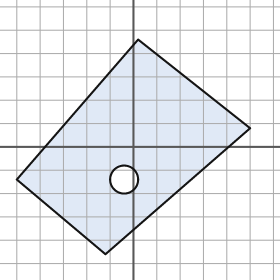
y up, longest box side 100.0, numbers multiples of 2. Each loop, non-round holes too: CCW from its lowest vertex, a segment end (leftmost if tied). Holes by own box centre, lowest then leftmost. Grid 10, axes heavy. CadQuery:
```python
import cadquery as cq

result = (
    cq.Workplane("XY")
    .moveTo(-12.0, -46.0)
    .lineTo(50.0, 8.0)
    .lineTo(2.0, 46.0)
    .lineTo(-50.0, -14.0)
    .close()
    .moveTo(-4.0, -14.0)
    .circle(6.0)
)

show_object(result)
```